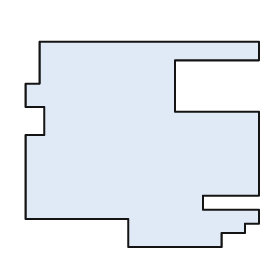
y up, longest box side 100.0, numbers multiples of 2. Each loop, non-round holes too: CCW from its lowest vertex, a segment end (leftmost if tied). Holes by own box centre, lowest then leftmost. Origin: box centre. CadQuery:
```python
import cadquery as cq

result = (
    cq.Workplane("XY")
    .moveTo(-6.0, -44.0)
    .lineTo(34.0, -44.0)
    .lineTo(34.0, -38.0)
    .lineTo(44.0, -38.0)
    .lineTo(44.0, -34.0)
    .lineTo(50.0, -34.0)
    .lineTo(50.0, -28.0)
    .lineTo(26.0, -28.0)
    .lineTo(26.0, -22.0)
    .lineTo(50.0, -22.0)
    .lineTo(50.0, 14.0)
    .lineTo(14.0, 14.0)
    .lineTo(14.0, 36.0)
    .lineTo(50.0, 36.0)
    .lineTo(50.0, 44.0)
    .lineTo(-44.0, 44.0)
    .lineTo(-44.0, 26.0)
    .lineTo(-50.0, 26.0)
    .lineTo(-50.0, 16.0)
    .lineTo(-42.0, 16.0)
    .lineTo(-42.0, 4.0)
    .lineTo(-50.0, 4.0)
    .lineTo(-50.0, -32.0)
    .lineTo(-6.0, -32.0)
    .close()
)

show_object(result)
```